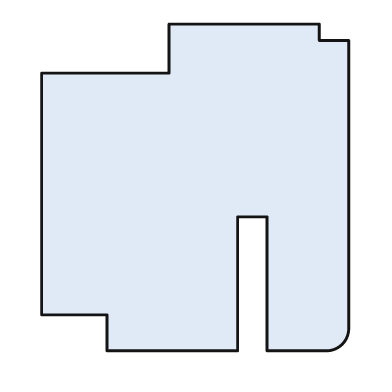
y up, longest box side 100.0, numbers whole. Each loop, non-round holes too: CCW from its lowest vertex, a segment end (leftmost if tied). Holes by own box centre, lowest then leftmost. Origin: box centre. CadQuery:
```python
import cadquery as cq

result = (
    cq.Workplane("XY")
    .moveTo(-27.0, -50.0)
    .lineTo(13.0, -50.0)
    .lineTo(13.0, -9.0)
    .lineTo(22.0, -9.0)
    .lineTo(22.0, -50.0)
    .lineTo(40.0, -50.0)
    .threePointArc((45.0, -48.0), (47.0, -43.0))
    .lineTo(47.0, 45.0)
    .lineTo(38.0, 45.0)
    .lineTo(38.0, 50.0)
    .lineTo(-8.0, 50.0)
    .lineTo(-8.0, 35.0)
    .lineTo(-47.0, 35.0)
    .lineTo(-47.0, -39.0)
    .lineTo(-27.0, -39.0)
    .close()
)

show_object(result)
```